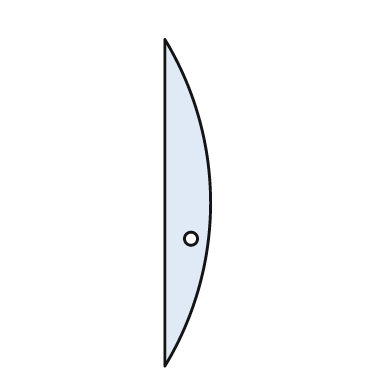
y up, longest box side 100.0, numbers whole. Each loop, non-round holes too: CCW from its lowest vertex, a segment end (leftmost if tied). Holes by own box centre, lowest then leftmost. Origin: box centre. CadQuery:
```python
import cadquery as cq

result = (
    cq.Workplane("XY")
    .moveTo(-7.0, -50.0)
    .threePointArc((7.0, 0.0), (-7.0, 50.0))
    .close()
    .moveTo(1.0, -11.0)
    .circle(2.0)
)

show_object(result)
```